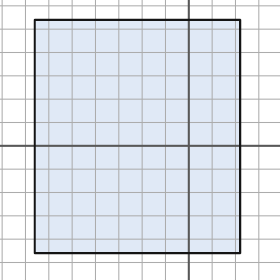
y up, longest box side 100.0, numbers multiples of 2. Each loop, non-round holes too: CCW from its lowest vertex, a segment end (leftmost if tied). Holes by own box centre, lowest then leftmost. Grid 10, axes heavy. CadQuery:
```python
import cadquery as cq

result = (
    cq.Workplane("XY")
    .moveTo(-66.0, -46.0)
    .lineTo(22.0, -46.0)
    .lineTo(22.0, 54.0)
    .lineTo(-66.0, 54.0)
    .close()
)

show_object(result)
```